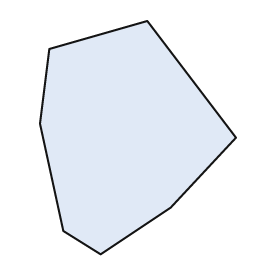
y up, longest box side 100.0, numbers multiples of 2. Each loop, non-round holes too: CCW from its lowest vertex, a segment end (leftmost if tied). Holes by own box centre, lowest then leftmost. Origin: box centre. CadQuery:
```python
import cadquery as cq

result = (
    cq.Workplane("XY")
    .moveTo(-16.0, -50.0)
    .lineTo(14.0, -30.0)
    .lineTo(42.0, 0.0)
    .lineTo(4.0, 50.0)
    .lineTo(-38.0, 38.0)
    .lineTo(-42.0, 6.0)
    .lineTo(-32.0, -40.0)
    .close()
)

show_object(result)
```